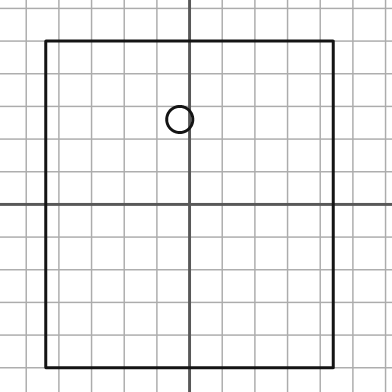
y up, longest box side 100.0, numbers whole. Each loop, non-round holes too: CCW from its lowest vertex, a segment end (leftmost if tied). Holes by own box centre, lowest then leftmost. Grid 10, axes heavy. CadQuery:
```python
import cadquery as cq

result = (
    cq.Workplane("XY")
    .moveTo(-44.0, -50.0)
    .lineTo(44.0, -50.0)
    .lineTo(44.0, 50.0)
    .lineTo(-44.0, 50.0)
    .close()
    .moveTo(-3.0, 26.0)
    .circle(4.0)
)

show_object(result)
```